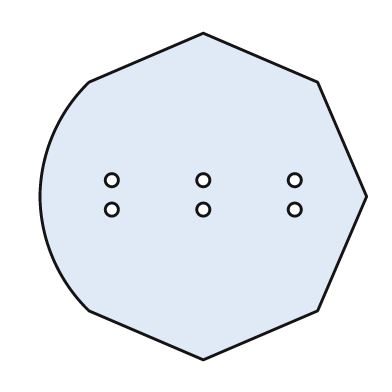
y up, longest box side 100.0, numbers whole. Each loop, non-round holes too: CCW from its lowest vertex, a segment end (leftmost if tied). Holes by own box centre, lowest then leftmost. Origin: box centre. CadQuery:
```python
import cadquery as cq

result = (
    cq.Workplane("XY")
    .moveTo(0.0, -50.0)
    .lineTo(35.0, -35.0)
    .lineTo(50.0, 0.0)
    .lineTo(35.0, 35.0)
    .lineTo(0.0, 50.0)
    .lineTo(-35.0, 35.0)
    .threePointArc((-46.0, 19.0), (-50.0, 0.0))
    .threePointArc((-46.0, -19.0), (-35.0, -35.0))
    .close()
    .moveTo(-28.0, -4.0)
    .circle(2.0)
    .moveTo(0.0, -4.0)
    .circle(2.0)
    .moveTo(28.0, -4.0)
    .circle(2.0)
    .moveTo(-28.0, 5.0)
    .circle(2.0)
    .moveTo(0.0, 5.0)
    .circle(2.0)
    .moveTo(28.0, 5.0)
    .circle(2.0)
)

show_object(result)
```